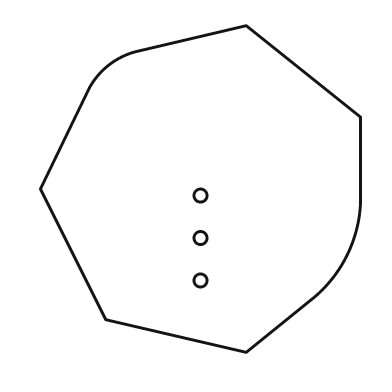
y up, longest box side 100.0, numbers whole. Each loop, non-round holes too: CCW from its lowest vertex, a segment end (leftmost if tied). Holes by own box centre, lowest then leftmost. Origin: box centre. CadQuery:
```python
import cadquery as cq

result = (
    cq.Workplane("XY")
    .moveTo(14.0, -50.0)
    .lineTo(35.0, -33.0)
    .threePointArc((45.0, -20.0), (49.0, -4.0))
    .lineTo(49.0, 22.0)
    .lineTo(14.0, 50.0)
    .lineTo(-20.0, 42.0)
    .threePointArc((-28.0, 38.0), (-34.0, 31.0))
    .lineTo(-49.0, 0.0)
    .lineTo(-29.0, -40.0)
    .close()
    .moveTo(0.0, -28.0)
    .circle(2.0)
    .moveTo(0.0, -15.0)
    .circle(2.0)
    .moveTo(0.0, -2.0)
    .circle(2.0)
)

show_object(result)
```